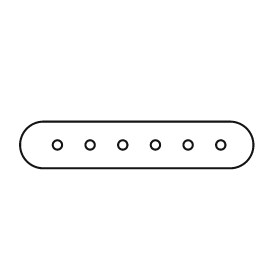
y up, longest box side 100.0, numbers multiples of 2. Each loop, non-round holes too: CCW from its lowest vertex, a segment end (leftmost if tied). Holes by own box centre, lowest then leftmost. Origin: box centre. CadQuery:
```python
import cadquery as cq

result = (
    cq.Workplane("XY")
    .moveTo(-40.0, -10.0)
    .lineTo(40.0, -10.0)
    .threePointArc((50.0, 0.0), (40.0, 10.0))
    .lineTo(-40.0, 10.0)
    .threePointArc((-50.0, 0.0), (-40.0, -10.0))
    .close()
    .moveTo(-34.0, 0.0)
    .circle(2.0)
    .moveTo(-20.0, 0.0)
    .circle(2.0)
    .moveTo(-6.0, 0.0)
    .circle(2.0)
    .moveTo(8.0, 0.0)
    .circle(2.0)
    .moveTo(22.0, 0.0)
    .circle(2.0)
    .moveTo(36.0, 0.0)
    .circle(2.0)
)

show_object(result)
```